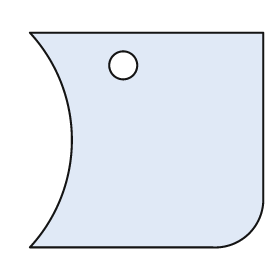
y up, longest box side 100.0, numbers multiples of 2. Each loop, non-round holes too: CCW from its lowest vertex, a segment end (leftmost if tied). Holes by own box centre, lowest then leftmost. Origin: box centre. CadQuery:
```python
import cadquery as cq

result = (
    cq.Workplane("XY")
    .moveTo(-50.0, -46.0)
    .lineTo(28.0, -46.0)
    .threePointArc((44.0, -40.0), (50.0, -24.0))
    .lineTo(50.0, 46.0)
    .lineTo(-50.0, 46.0)
    .threePointArc((-32.0, 0.0), (-50.0, -46.0))
    .close()
    .moveTo(-10.0, 32.0)
    .circle(6.0)
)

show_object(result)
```